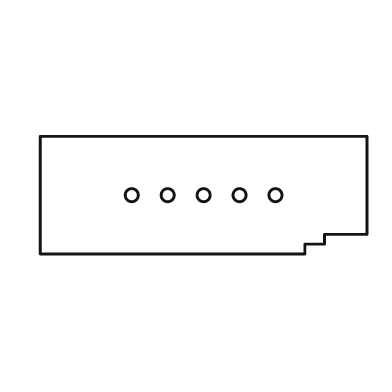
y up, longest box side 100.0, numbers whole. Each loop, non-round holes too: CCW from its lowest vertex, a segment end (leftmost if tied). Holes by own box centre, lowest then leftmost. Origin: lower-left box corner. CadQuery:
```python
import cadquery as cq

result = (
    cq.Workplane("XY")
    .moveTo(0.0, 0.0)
    .lineTo(81.0, 0.0)
    .lineTo(81.0, 3.0)
    .lineTo(87.0, 3.0)
    .lineTo(87.0, 6.0)
    .lineTo(100.0, 6.0)
    .lineTo(100.0, 36.0)
    .lineTo(0.0, 36.0)
    .close()
    .moveTo(28.0, 18.0)
    .circle(2.0)
    .moveTo(39.0, 18.0)
    .circle(2.0)
    .moveTo(50.0, 18.0)
    .circle(2.0)
    .moveTo(61.0, 18.0)
    .circle(2.0)
    .moveTo(72.0, 18.0)
    .circle(2.0)
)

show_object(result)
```